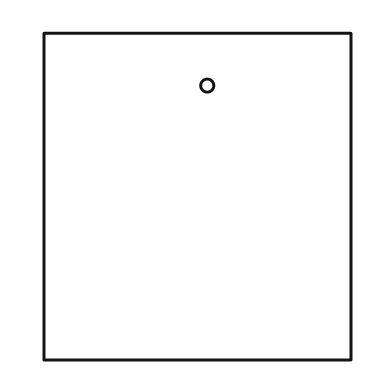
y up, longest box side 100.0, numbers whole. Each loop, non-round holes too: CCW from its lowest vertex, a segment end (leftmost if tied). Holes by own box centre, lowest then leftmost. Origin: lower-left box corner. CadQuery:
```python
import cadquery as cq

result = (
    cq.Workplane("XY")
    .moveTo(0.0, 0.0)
    .lineTo(94.0, 0.0)
    .lineTo(94.0, 100.0)
    .lineTo(0.0, 100.0)
    .close()
    .moveTo(50.0, 84.0)
    .circle(2.0)
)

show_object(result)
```